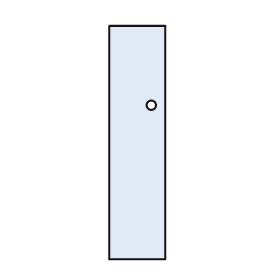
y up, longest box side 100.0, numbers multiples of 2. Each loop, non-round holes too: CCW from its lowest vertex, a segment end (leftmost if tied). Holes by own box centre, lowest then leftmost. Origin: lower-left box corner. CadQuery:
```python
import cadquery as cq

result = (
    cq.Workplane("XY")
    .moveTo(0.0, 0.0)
    .lineTo(24.0, 0.0)
    .lineTo(24.0, 100.0)
    .lineTo(0.0, 100.0)
    .close()
    .moveTo(18.0, 66.0)
    .circle(2.0)
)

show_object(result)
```